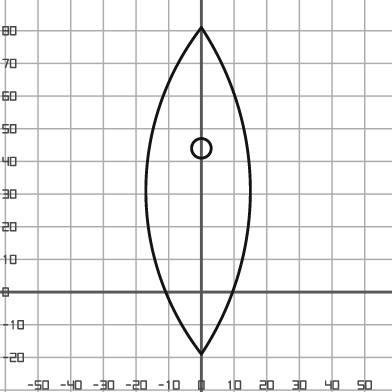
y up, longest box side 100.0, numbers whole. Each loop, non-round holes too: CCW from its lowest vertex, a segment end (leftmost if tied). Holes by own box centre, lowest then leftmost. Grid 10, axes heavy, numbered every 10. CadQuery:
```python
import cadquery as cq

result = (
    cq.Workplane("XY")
    .moveTo(0.0, -19.0)
    .threePointArc((15.0, 31.0), (0.0, 81.0))
    .threePointArc((-17.0, 31.0), (0.0, -19.0))
    .close()
    .moveTo(0.0, 44.0)
    .circle(3.0)
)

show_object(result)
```